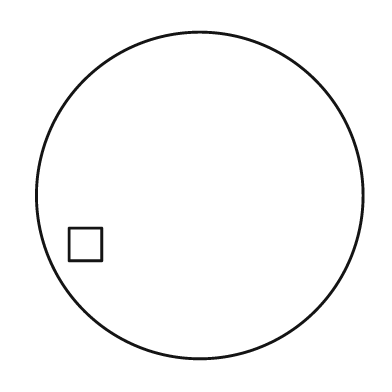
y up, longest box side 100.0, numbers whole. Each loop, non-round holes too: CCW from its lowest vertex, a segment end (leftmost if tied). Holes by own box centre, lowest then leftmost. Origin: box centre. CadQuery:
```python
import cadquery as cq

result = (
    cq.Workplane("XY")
    .moveTo(0.0, 0.0)
    .circle(50.0)
    .moveTo(-40.0, -20.0)
    .lineTo(-30.0, -20.0)
    .lineTo(-30.0, -10.0)
    .lineTo(-40.0, -10.0)
    .close()
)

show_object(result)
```